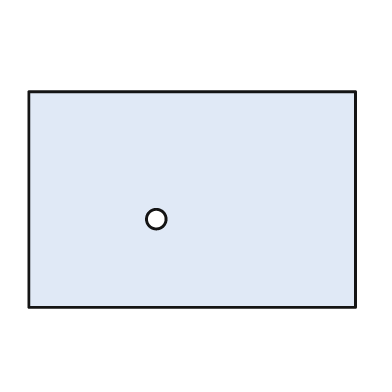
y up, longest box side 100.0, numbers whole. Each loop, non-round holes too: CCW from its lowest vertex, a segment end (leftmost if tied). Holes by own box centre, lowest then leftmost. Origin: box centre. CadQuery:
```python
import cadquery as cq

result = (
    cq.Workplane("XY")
    .moveTo(-50.0, -33.0)
    .lineTo(50.0, -33.0)
    .lineTo(50.0, 33.0)
    .lineTo(-50.0, 33.0)
    .close()
    .moveTo(-11.0, -6.0)
    .circle(3.0)
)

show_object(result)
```